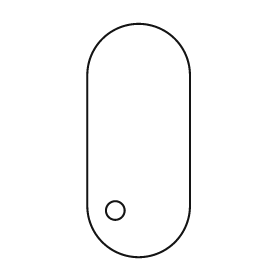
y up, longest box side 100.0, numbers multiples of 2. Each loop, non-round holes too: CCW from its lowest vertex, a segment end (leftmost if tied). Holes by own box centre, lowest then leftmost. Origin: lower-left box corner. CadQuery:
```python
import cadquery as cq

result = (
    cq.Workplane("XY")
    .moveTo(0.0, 22.0)
    .threePointArc((22.0, 0.0), (44.0, 22.0))
    .lineTo(44.0, 78.0)
    .threePointArc((22.0, 100.0), (0.0, 78.0))
    .close()
    .moveTo(12.0, 20.0)
    .circle(4.0)
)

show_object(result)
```